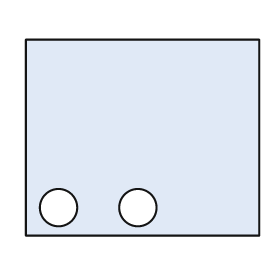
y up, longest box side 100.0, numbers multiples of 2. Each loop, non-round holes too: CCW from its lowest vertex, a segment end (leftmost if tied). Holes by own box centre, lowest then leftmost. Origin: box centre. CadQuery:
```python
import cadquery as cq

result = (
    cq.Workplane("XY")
    .moveTo(-50.0, -42.0)
    .lineTo(50.0, -42.0)
    .lineTo(50.0, 42.0)
    .lineTo(-50.0, 42.0)
    .close()
    .moveTo(-36.0, -30.0)
    .circle(8.0)
    .moveTo(-2.0, -30.0)
    .circle(8.0)
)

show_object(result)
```